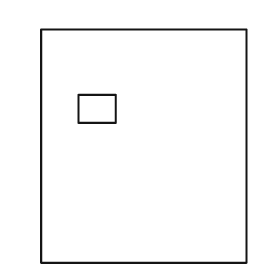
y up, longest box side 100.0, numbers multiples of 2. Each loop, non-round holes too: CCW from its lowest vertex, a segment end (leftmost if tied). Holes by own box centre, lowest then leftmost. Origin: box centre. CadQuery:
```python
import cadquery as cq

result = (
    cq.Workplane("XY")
    .moveTo(-44.0, -50.0)
    .lineTo(44.0, -50.0)
    .lineTo(44.0, 50.0)
    .lineTo(-44.0, 50.0)
    .close()
    .moveTo(-28.0, 10.0)
    .lineTo(-12.0, 10.0)
    .lineTo(-12.0, 22.0)
    .lineTo(-28.0, 22.0)
    .close()
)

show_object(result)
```